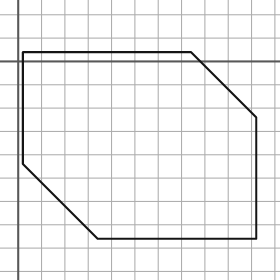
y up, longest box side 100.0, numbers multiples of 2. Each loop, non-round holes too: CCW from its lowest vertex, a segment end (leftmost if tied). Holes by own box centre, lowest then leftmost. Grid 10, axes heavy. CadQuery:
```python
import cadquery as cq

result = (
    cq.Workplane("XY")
    .moveTo(34.0, -76.0)
    .lineTo(102.0, -76.0)
    .lineTo(102.0, -24.0)
    .lineTo(74.0, 4.0)
    .lineTo(2.0, 4.0)
    .lineTo(2.0, -44.0)
    .close()
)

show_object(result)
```